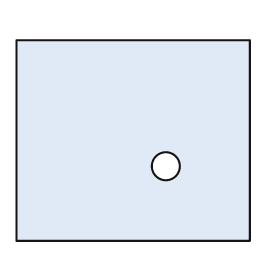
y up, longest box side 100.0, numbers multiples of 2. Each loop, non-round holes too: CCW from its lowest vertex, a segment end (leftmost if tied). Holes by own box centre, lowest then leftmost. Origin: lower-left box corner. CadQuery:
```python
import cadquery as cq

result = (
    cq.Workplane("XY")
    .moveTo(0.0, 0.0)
    .lineTo(100.0, 0.0)
    .lineTo(100.0, 86.0)
    .lineTo(0.0, 86.0)
    .close()
    .moveTo(64.0, 32.0)
    .circle(6.0)
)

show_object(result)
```